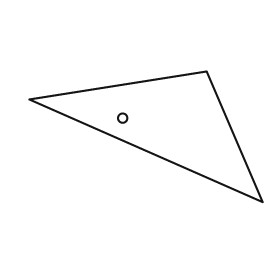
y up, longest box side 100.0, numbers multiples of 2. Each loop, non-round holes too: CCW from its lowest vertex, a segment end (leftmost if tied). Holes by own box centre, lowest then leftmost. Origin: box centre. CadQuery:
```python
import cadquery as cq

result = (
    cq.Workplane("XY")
    .moveTo(50.0, -28.0)
    .lineTo(26.0, 28.0)
    .lineTo(-50.0, 16.0)
    .close()
    .moveTo(-10.0, 8.0)
    .circle(2.0)
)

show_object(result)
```